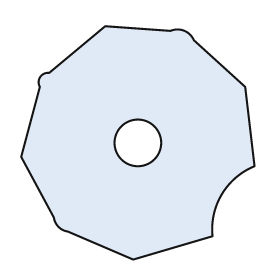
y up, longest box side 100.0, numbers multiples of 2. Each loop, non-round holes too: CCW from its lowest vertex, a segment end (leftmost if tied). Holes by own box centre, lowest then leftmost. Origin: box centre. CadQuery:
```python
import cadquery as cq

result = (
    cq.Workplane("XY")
    .moveTo(-2.0, -50.0)
    .lineTo(32.0, -40.0)
    .threePointArc((36.0, -22.0), (50.0, -10.0))
    .lineTo(46.0, 24.0)
    .lineTo(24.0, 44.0)
    .threePointArc((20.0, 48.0), (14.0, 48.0))
    .lineTo(-14.0, 50.0)
    .lineTo(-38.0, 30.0)
    .threePointArc((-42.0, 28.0), (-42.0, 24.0))
    .lineTo(-50.0, -6.0)
    .lineTo(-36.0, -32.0)
    .threePointArc((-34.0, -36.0), (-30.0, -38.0))
    .close()
    .moveTo(0.0, 0.0)
    .circle(10.0)
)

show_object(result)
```